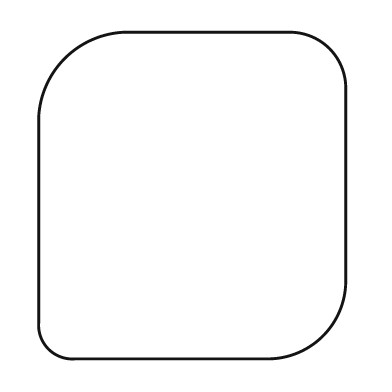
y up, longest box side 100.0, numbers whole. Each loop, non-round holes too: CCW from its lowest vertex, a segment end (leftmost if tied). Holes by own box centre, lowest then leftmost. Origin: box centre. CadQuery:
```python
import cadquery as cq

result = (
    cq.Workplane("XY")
    .moveTo(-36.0, -50.0)
    .lineTo(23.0, -50.0)
    .threePointArc((40.0, -43.0), (47.0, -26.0))
    .lineTo(47.0, 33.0)
    .threePointArc((42.0, 45.0), (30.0, 50.0))
    .lineTo(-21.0, 50.0)
    .threePointArc((-39.0, 42.0), (-47.0, 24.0))
    .lineTo(-47.0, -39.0)
    .threePointArc((-44.0, -47.0), (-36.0, -50.0))
    .close()
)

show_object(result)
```